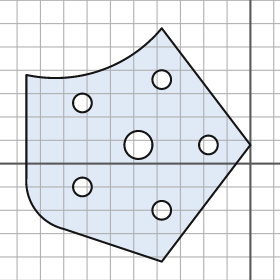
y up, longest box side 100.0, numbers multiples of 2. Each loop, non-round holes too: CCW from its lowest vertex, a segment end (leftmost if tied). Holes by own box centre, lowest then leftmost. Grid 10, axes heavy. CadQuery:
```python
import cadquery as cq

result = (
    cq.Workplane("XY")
    .moveTo(-38.0, -42.0)
    .lineTo(0.0, 8.0)
    .lineTo(-38.0, 58.0)
    .threePointArc((-64.0, 40.0), (-96.0, 38.0))
    .lineTo(-96.0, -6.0)
    .threePointArc((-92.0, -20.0), (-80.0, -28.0))
    .close()
    .moveTo(-38.0, -20.0)
    .circle(4.0)
    .moveTo(-72.0, -10.0)
    .circle(4.0)
    .moveTo(-48.0, 8.0)
    .circle(6.0)
    .moveTo(-18.0, 8.0)
    .circle(4.0)
    .moveTo(-72.0, 26.0)
    .circle(4.0)
    .moveTo(-38.0, 36.0)
    .circle(4.0)
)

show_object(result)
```